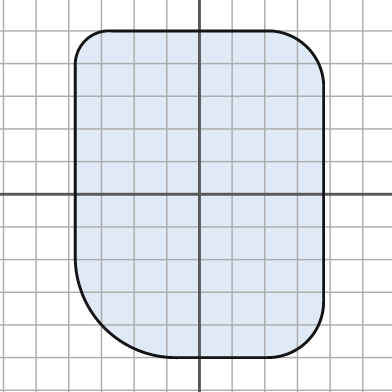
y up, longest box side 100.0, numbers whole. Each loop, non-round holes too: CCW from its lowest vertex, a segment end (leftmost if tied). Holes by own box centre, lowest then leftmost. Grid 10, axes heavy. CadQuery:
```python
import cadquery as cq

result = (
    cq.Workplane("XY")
    .moveTo(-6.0, -50.0)
    .lineTo(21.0, -50.0)
    .threePointArc((33.0, -45.0), (38.0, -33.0))
    .lineTo(38.0, 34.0)
    .threePointArc((33.0, 45.0), (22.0, 50.0))
    .lineTo(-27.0, 50.0)
    .threePointArc((-35.0, 47.0), (-38.0, 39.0))
    .lineTo(-38.0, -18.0)
    .threePointArc((-29.0, -41.0), (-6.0, -50.0))
    .close()
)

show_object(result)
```